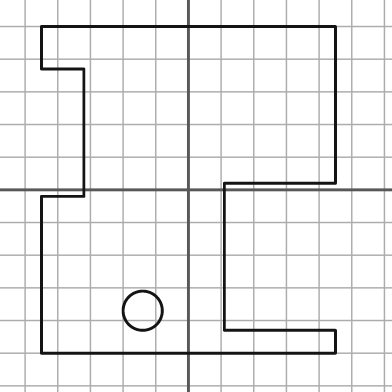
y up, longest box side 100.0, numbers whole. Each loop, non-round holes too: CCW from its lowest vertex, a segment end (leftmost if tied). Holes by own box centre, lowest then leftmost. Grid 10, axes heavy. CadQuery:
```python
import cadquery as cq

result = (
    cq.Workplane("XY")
    .moveTo(-45.0, -50.0)
    .lineTo(45.0, -50.0)
    .lineTo(45.0, -43.0)
    .lineTo(11.0, -43.0)
    .lineTo(11.0, 2.0)
    .lineTo(45.0, 2.0)
    .lineTo(45.0, 50.0)
    .lineTo(-45.0, 50.0)
    .lineTo(-45.0, 37.0)
    .lineTo(-32.0, 37.0)
    .lineTo(-32.0, -2.0)
    .lineTo(-45.0, -2.0)
    .close()
    .moveTo(-14.0, -37.0)
    .circle(6.0)
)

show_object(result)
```